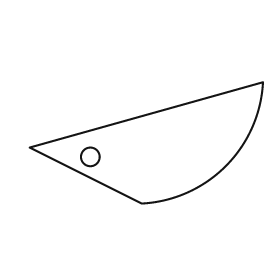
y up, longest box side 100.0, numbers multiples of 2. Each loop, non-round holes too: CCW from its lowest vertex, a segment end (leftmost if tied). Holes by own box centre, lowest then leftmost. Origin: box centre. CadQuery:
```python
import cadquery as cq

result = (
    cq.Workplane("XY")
    .moveTo(-2.0, -26.0)
    .threePointArc((34.0, -10.0), (50.0, 26.0))
    .lineTo(-50.0, -2.0)
    .close()
    .moveTo(-24.0, -6.0)
    .circle(4.0)
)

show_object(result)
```